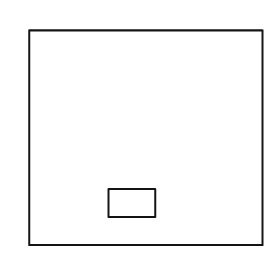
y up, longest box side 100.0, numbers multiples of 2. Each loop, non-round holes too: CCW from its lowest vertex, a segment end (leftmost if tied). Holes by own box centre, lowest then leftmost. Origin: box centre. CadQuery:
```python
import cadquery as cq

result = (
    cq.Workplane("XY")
    .moveTo(-50.0, -46.0)
    .lineTo(50.0, -46.0)
    .lineTo(50.0, 46.0)
    .lineTo(-50.0, 46.0)
    .close()
    .moveTo(-16.0, -34.0)
    .lineTo(4.0, -34.0)
    .lineTo(4.0, -22.0)
    .lineTo(-16.0, -22.0)
    .close()
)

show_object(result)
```